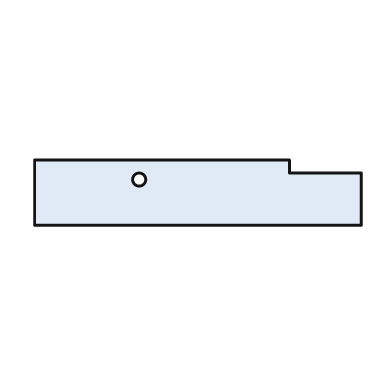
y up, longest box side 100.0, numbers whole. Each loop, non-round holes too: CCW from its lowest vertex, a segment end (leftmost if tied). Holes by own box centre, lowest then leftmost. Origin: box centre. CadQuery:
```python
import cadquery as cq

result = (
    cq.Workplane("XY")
    .moveTo(-50.0, -10.0)
    .lineTo(50.0, -10.0)
    .lineTo(50.0, 6.0)
    .lineTo(28.0, 6.0)
    .lineTo(28.0, 10.0)
    .lineTo(-50.0, 10.0)
    .close()
    .moveTo(-18.0, 4.0)
    .circle(2.0)
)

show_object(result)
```